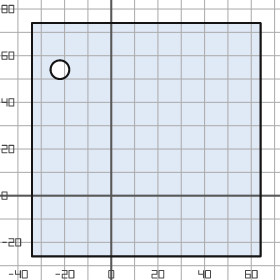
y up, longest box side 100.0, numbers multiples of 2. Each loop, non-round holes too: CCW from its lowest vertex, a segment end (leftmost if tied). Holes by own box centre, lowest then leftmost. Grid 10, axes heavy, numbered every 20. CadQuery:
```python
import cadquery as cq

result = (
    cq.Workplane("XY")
    .moveTo(-34.0, -26.0)
    .lineTo(64.0, -26.0)
    .lineTo(64.0, 74.0)
    .lineTo(-34.0, 74.0)
    .close()
    .moveTo(-22.0, 54.0)
    .circle(4.0)
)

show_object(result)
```